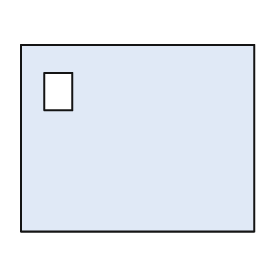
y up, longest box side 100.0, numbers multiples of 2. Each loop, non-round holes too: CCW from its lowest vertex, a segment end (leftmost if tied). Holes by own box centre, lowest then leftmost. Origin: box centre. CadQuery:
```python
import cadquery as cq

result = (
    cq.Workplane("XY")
    .moveTo(-50.0, -40.0)
    .lineTo(50.0, -40.0)
    .lineTo(50.0, 40.0)
    .lineTo(-50.0, 40.0)
    .close()
    .moveTo(-40.0, 12.0)
    .lineTo(-28.0, 12.0)
    .lineTo(-28.0, 28.0)
    .lineTo(-40.0, 28.0)
    .close()
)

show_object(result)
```